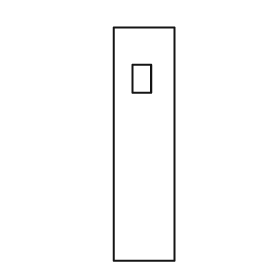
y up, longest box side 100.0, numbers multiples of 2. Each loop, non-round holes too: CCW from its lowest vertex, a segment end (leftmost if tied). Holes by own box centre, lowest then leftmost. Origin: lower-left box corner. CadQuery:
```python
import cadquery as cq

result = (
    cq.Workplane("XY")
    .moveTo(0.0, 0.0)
    .lineTo(26.0, 0.0)
    .lineTo(26.0, 100.0)
    .lineTo(0.0, 100.0)
    .close()
    .moveTo(8.0, 72.0)
    .lineTo(16.0, 72.0)
    .lineTo(16.0, 84.0)
    .lineTo(8.0, 84.0)
    .close()
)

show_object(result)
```